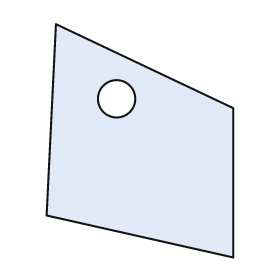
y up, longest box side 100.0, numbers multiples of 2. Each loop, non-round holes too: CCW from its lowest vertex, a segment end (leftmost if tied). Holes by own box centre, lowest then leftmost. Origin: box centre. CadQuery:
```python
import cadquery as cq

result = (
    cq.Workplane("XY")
    .moveTo(40.0, -50.0)
    .lineTo(40.0, 14.0)
    .lineTo(-36.0, 50.0)
    .lineTo(-40.0, -32.0)
    .close()
    .moveTo(-10.0, 18.0)
    .circle(8.0)
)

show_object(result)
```